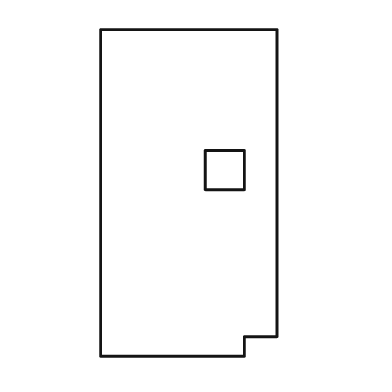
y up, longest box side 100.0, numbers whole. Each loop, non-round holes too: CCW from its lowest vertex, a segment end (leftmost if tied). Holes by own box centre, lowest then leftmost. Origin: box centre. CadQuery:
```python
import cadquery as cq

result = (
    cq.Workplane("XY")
    .moveTo(-27.0, -50.0)
    .lineTo(17.0, -50.0)
    .lineTo(17.0, -44.0)
    .lineTo(27.0, -44.0)
    .lineTo(27.0, 50.0)
    .lineTo(-27.0, 50.0)
    .close()
    .moveTo(5.0, 1.0)
    .lineTo(17.0, 1.0)
    .lineTo(17.0, 13.0)
    .lineTo(5.0, 13.0)
    .close()
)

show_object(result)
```